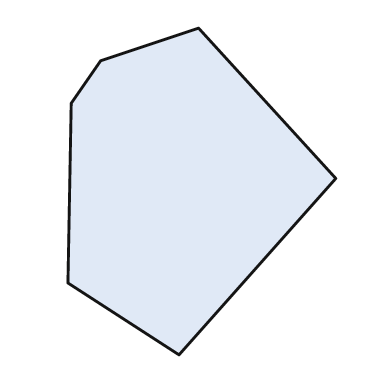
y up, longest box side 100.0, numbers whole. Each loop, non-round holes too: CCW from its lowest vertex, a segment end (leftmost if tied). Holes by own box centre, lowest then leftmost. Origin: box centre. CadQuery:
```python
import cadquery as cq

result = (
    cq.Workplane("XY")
    .moveTo(-7.0, -50.0)
    .lineTo(41.0, 4.0)
    .lineTo(-1.0, 50.0)
    .lineTo(-31.0, 40.0)
    .lineTo(-40.0, 27.0)
    .lineTo(-41.0, -28.0)
    .close()
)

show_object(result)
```